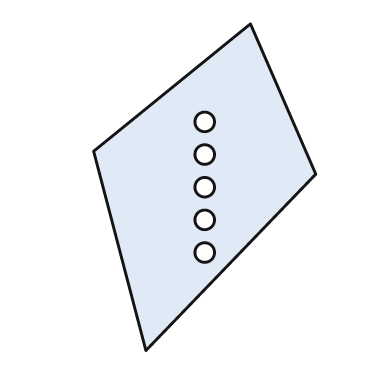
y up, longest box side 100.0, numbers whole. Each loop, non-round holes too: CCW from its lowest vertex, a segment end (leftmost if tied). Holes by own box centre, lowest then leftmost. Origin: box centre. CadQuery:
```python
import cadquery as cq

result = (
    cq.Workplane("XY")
    .moveTo(-18.0, -50.0)
    .lineTo(34.0, 4.0)
    .lineTo(14.0, 50.0)
    .lineTo(-34.0, 11.0)
    .close()
    .moveTo(0.0, -20.0)
    .circle(3.0)
    .moveTo(0.0, -10.0)
    .circle(3.0)
    .moveTo(0.0, 0.0)
    .circle(3.0)
    .moveTo(0.0, 10.0)
    .circle(3.0)
    .moveTo(0.0, 20.0)
    .circle(3.0)
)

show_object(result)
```